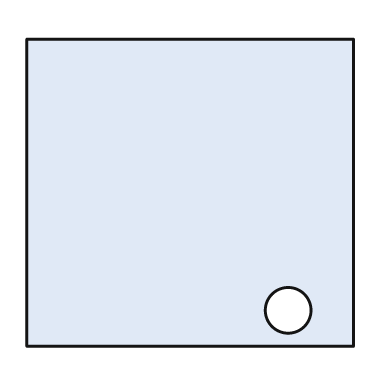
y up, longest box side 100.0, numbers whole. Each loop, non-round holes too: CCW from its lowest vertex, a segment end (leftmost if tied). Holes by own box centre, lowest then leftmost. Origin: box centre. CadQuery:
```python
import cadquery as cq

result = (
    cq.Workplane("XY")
    .moveTo(-50.0, -47.0)
    .lineTo(50.0, -47.0)
    .lineTo(50.0, 47.0)
    .lineTo(-50.0, 47.0)
    .close()
    .moveTo(30.0, -36.0)
    .circle(7.0)
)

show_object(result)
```